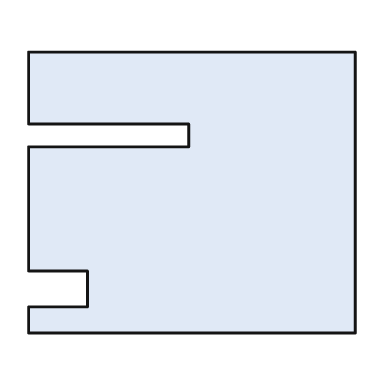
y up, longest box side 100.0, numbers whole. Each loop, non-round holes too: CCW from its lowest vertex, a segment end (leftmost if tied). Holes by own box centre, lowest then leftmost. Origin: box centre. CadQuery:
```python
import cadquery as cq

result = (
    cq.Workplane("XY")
    .moveTo(-50.0, -43.0)
    .lineTo(50.0, -43.0)
    .lineTo(50.0, 43.0)
    .lineTo(-50.0, 43.0)
    .lineTo(-50.0, 21.0)
    .lineTo(-1.0, 21.0)
    .lineTo(-1.0, 14.0)
    .lineTo(-50.0, 14.0)
    .lineTo(-50.0, -24.0)
    .lineTo(-32.0, -24.0)
    .lineTo(-32.0, -35.0)
    .lineTo(-50.0, -35.0)
    .close()
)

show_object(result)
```